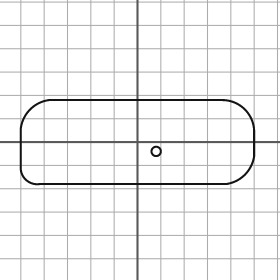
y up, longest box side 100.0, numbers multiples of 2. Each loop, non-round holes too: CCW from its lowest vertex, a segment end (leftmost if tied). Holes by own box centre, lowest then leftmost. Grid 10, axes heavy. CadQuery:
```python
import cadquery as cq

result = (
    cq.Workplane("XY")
    .moveTo(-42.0, -18.0)
    .lineTo(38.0, -18.0)
    .threePointArc((46.0, -14.0), (50.0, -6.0))
    .lineTo(50.0, 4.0)
    .threePointArc((46.0, 14.0), (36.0, 18.0))
    .lineTo(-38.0, 18.0)
    .threePointArc((-46.0, 14.0), (-50.0, 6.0))
    .lineTo(-50.0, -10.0)
    .threePointArc((-48.0, -16.0), (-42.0, -18.0))
    .close()
    .moveTo(8.0, -4.0)
    .circle(2.0)
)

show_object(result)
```